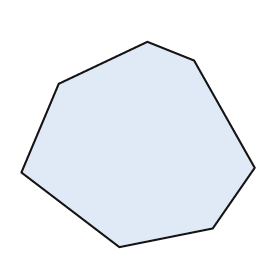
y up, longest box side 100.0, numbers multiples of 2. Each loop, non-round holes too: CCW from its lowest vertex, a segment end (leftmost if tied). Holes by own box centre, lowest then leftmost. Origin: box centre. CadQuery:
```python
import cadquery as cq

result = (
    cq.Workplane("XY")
    .moveTo(-8.0, -44.0)
    .lineTo(32.0, -36.0)
    .lineTo(50.0, -10.0)
    .lineTo(24.0, 36.0)
    .lineTo(4.0, 44.0)
    .lineTo(-34.0, 26.0)
    .lineTo(-50.0, -12.0)
    .close()
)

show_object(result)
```